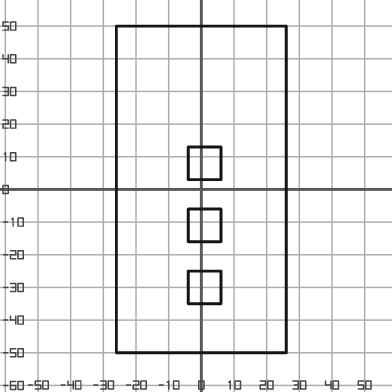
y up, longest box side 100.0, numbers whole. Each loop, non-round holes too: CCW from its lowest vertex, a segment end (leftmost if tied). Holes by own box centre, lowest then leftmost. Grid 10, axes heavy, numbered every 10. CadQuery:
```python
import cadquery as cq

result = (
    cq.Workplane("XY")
    .moveTo(-26.0, -50.0)
    .lineTo(26.0, -50.0)
    .lineTo(26.0, 50.0)
    .lineTo(-26.0, 50.0)
    .close()
    .moveTo(-4.0, -35.0)
    .lineTo(6.0, -35.0)
    .lineTo(6.0, -25.0)
    .lineTo(-4.0, -25.0)
    .close()
    .moveTo(-4.0, -16.0)
    .lineTo(6.0, -16.0)
    .lineTo(6.0, -6.0)
    .lineTo(-4.0, -6.0)
    .close()
    .moveTo(-4.0, 3.0)
    .lineTo(6.0, 3.0)
    .lineTo(6.0, 13.0)
    .lineTo(-4.0, 13.0)
    .close()
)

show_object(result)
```